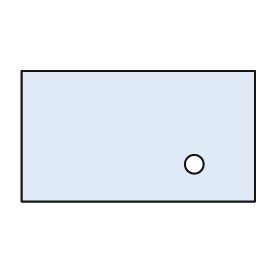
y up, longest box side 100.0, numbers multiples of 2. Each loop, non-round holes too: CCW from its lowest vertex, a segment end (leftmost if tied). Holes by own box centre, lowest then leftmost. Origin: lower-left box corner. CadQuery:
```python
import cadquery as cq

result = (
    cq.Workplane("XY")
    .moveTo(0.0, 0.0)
    .lineTo(100.0, 0.0)
    .lineTo(100.0, 56.0)
    .lineTo(0.0, 56.0)
    .close()
    .moveTo(74.0, 16.0)
    .circle(4.0)
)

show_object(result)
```